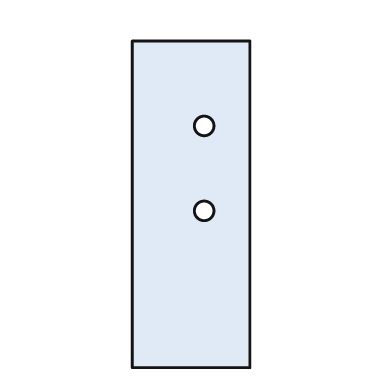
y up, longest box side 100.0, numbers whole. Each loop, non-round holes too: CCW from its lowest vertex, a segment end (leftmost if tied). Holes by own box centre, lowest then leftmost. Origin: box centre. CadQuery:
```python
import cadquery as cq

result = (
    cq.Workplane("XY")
    .moveTo(-18.0, -50.0)
    .lineTo(18.0, -50.0)
    .lineTo(18.0, 50.0)
    .lineTo(-18.0, 50.0)
    .close()
    .moveTo(4.0, -2.0)
    .circle(3.0)
    .moveTo(4.0, 24.0)
    .circle(3.0)
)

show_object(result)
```